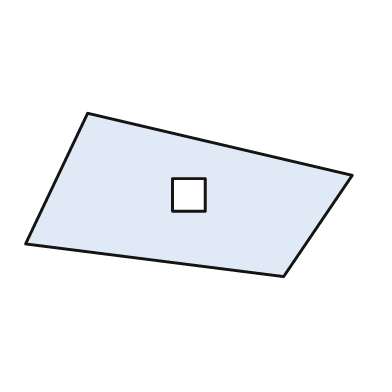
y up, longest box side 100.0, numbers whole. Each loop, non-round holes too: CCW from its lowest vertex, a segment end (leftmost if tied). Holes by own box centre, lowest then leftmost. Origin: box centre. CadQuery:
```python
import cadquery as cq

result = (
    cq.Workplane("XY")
    .moveTo(29.0, -25.0)
    .lineTo(50.0, 6.0)
    .lineTo(-31.0, 25.0)
    .lineTo(-50.0, -15.0)
    .close()
    .moveTo(-5.0, -5.0)
    .lineTo(5.0, -5.0)
    .lineTo(5.0, 5.0)
    .lineTo(-5.0, 5.0)
    .close()
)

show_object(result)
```